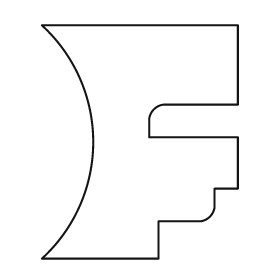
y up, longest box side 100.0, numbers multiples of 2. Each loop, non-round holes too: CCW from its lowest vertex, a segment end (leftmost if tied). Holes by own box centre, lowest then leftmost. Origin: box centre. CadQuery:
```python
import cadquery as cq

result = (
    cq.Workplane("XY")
    .moveTo(-42.0, -50.0)
    .lineTo(8.0, -50.0)
    .lineTo(8.0, -34.0)
    .lineTo(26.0, -34.0)
    .threePointArc((30.0, -32.0), (32.0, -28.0))
    .lineTo(32.0, -20.0)
    .lineTo(42.0, -20.0)
    .lineTo(42.0, 2.0)
    .lineTo(4.0, 2.0)
    .lineTo(4.0, 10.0)
    .threePointArc((6.0, 14.0), (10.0, 16.0))
    .lineTo(42.0, 16.0)
    .lineTo(42.0, 50.0)
    .lineTo(-42.0, 50.0)
    .threePointArc((-20.0, 0.0), (-42.0, -50.0))
    .close()
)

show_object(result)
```